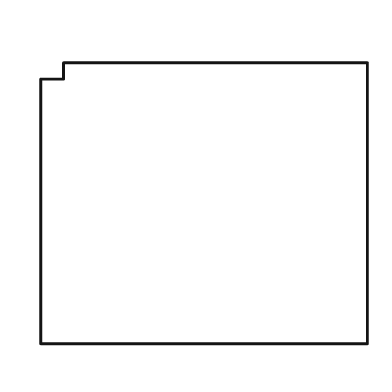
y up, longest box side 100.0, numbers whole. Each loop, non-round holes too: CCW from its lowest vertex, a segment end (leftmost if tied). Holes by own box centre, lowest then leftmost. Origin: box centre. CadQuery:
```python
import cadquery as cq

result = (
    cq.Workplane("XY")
    .moveTo(-50.0, -43.0)
    .lineTo(50.0, -43.0)
    .lineTo(50.0, 43.0)
    .lineTo(-43.0, 43.0)
    .lineTo(-43.0, 38.0)
    .lineTo(-50.0, 38.0)
    .close()
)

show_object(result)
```